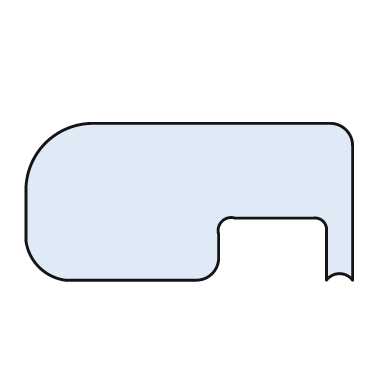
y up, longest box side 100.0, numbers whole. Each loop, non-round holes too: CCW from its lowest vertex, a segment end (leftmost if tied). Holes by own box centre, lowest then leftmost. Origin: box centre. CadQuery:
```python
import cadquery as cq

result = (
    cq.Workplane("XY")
    .moveTo(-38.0, -24.0)
    .lineTo(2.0, -24.0)
    .threePointArc((7.0, -22.0), (9.0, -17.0))
    .lineTo(9.0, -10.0)
    .threePointArc((10.0, -6.0), (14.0, -5.0))
    .lineTo(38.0, -5.0)
    .threePointArc((41.0, -6.0), (42.0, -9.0))
    .lineTo(42.0, -24.0)
    .threePointArc((46.0, -22.0), (50.0, -24.0))
    .lineTo(50.0, 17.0)
    .threePointArc((48.0, 22.0), (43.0, 24.0))
    .lineTo(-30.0, 24.0)
    .threePointArc((-44.0, 18.0), (-50.0, 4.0))
    .lineTo(-50.0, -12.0)
    .threePointArc((-46.0, -20.0), (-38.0, -24.0))
    .close()
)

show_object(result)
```